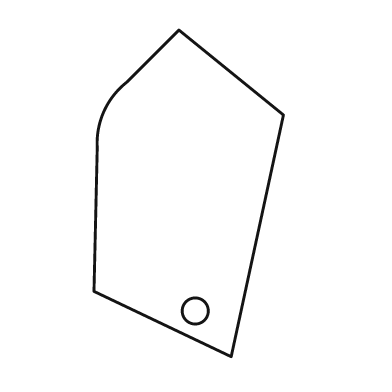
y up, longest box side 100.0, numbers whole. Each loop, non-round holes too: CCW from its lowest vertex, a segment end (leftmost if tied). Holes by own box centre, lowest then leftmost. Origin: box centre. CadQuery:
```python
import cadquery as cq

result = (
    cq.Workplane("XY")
    .moveTo(13.0, -50.0)
    .lineTo(29.0, 24.0)
    .lineTo(-3.0, 50.0)
    .lineTo(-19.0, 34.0)
    .threePointArc((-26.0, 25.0), (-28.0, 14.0))
    .lineTo(-29.0, -30.0)
    .close()
    .moveTo(2.0, -36.0)
    .circle(4.0)
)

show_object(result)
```